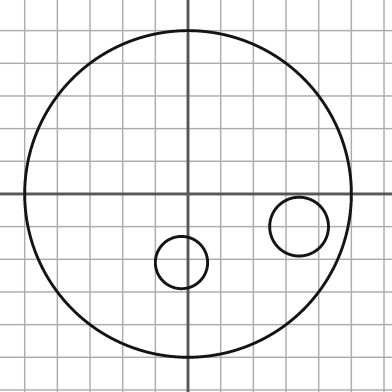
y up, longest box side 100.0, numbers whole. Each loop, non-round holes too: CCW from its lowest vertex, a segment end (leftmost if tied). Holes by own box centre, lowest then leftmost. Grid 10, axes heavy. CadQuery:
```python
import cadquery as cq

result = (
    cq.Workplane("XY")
    .moveTo(0.0, 0.0)
    .circle(50.0)
    .moveTo(-2.0, -21.0)
    .circle(8.0)
    .moveTo(34.0, -10.0)
    .circle(9.0)
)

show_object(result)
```